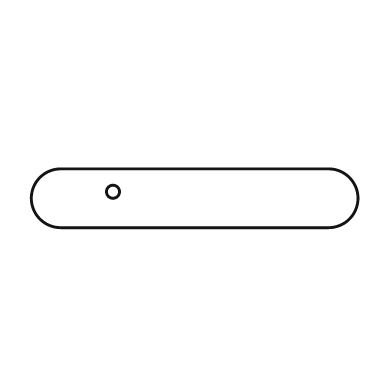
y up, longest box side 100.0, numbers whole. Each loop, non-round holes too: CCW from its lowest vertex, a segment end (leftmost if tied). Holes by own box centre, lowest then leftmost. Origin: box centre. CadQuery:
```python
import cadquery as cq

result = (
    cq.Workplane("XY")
    .moveTo(-41.0, -9.0)
    .lineTo(41.0, -9.0)
    .threePointArc((50.0, 0.0), (41.0, 9.0))
    .lineTo(-41.0, 9.0)
    .threePointArc((-50.0, 0.0), (-41.0, -9.0))
    .close()
    .moveTo(-25.0, 2.0)
    .circle(2.0)
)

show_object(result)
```